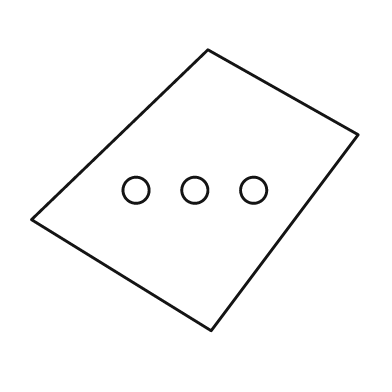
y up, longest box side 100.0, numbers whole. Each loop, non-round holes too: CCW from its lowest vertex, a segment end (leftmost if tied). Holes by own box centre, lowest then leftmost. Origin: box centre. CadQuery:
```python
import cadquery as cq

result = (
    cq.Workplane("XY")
    .moveTo(5.0, -43.0)
    .lineTo(50.0, 17.0)
    .lineTo(4.0, 43.0)
    .lineTo(-50.0, -9.0)
    .close()
    .moveTo(-18.0, 0.0)
    .circle(4.0)
    .moveTo(0.0, 0.0)
    .circle(4.0)
    .moveTo(18.0, 0.0)
    .circle(4.0)
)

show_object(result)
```